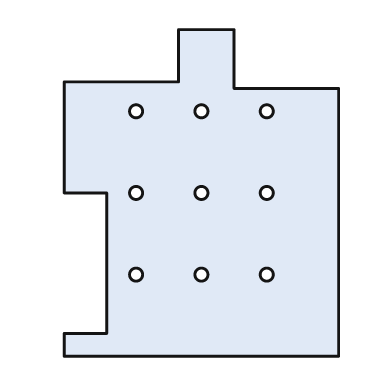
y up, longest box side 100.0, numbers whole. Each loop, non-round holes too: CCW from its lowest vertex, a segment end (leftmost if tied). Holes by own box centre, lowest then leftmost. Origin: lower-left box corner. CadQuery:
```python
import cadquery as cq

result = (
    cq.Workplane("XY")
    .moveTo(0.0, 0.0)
    .lineTo(84.0, 0.0)
    .lineTo(84.0, 82.0)
    .lineTo(52.0, 82.0)
    .lineTo(52.0, 100.0)
    .lineTo(35.0, 100.0)
    .lineTo(35.0, 84.0)
    .lineTo(0.0, 84.0)
    .lineTo(0.0, 50.0)
    .lineTo(13.0, 50.0)
    .lineTo(13.0, 7.0)
    .lineTo(0.0, 7.0)
    .close()
    .moveTo(22.0, 25.0)
    .circle(2.0)
    .moveTo(42.0, 25.0)
    .circle(2.0)
    .moveTo(62.0, 25.0)
    .circle(2.0)
    .moveTo(22.0, 50.0)
    .circle(2.0)
    .moveTo(42.0, 50.0)
    .circle(2.0)
    .moveTo(62.0, 50.0)
    .circle(2.0)
    .moveTo(22.0, 75.0)
    .circle(2.0)
    .moveTo(42.0, 75.0)
    .circle(2.0)
    .moveTo(62.0, 75.0)
    .circle(2.0)
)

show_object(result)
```